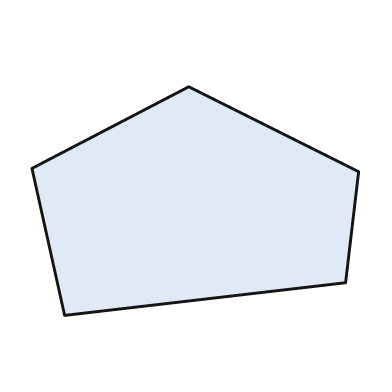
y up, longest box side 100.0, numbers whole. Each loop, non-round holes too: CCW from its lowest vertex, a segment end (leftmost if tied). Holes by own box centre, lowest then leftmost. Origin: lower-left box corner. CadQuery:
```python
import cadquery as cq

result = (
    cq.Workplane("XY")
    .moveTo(10.0, 0.0)
    .lineTo(96.0, 10.0)
    .lineTo(100.0, 44.0)
    .lineTo(48.0, 70.0)
    .lineTo(0.0, 45.0)
    .close()
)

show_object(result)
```